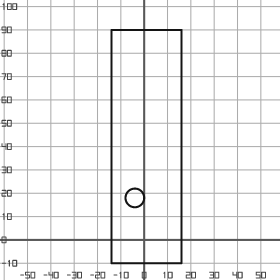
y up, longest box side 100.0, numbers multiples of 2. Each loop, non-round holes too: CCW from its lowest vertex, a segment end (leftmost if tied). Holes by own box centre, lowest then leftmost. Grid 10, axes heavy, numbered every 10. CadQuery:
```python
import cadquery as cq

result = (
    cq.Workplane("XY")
    .moveTo(-14.0, -10.0)
    .lineTo(16.0, -10.0)
    .lineTo(16.0, 90.0)
    .lineTo(-14.0, 90.0)
    .close()
    .moveTo(-4.0, 18.0)
    .circle(4.0)
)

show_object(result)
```